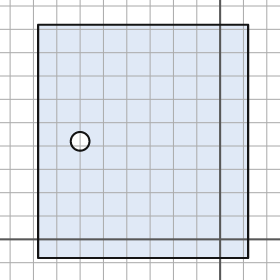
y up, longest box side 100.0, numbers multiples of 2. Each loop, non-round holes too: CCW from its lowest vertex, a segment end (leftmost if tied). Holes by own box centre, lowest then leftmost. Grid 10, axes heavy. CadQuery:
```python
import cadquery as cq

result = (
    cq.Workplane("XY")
    .moveTo(-78.0, -8.0)
    .lineTo(12.0, -8.0)
    .lineTo(12.0, 92.0)
    .lineTo(-78.0, 92.0)
    .close()
    .moveTo(-60.0, 42.0)
    .circle(4.0)
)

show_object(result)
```